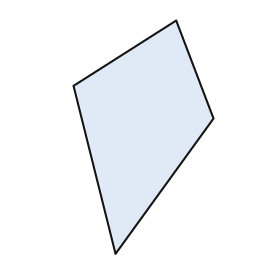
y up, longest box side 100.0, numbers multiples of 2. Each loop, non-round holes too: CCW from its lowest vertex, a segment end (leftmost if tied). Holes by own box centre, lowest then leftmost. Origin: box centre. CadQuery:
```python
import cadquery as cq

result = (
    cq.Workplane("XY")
    .moveTo(-12.0, -50.0)
    .lineTo(30.0, 8.0)
    .lineTo(14.0, 50.0)
    .lineTo(-30.0, 22.0)
    .close()
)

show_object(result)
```